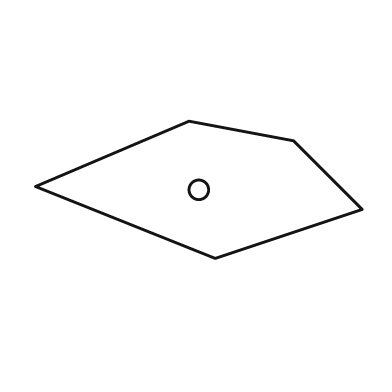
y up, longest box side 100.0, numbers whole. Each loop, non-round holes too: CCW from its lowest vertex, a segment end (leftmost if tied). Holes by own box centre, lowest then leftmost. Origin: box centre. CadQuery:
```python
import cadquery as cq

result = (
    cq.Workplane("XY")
    .moveTo(5.0, -21.0)
    .lineTo(50.0, -6.0)
    .lineTo(29.0, 15.0)
    .lineTo(-3.0, 21.0)
    .lineTo(-50.0, 1.0)
    .close()
    .moveTo(0.0, 0.0)
    .circle(3.0)
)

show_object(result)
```